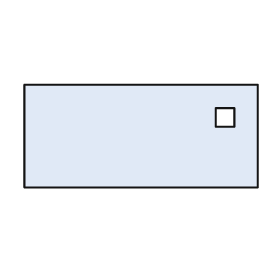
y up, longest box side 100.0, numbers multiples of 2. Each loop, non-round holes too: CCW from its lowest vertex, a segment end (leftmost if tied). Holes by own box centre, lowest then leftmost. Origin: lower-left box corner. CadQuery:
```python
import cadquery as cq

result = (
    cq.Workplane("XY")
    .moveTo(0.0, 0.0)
    .lineTo(100.0, 0.0)
    .lineTo(100.0, 44.0)
    .lineTo(0.0, 44.0)
    .close()
    .moveTo(82.0, 26.0)
    .lineTo(90.0, 26.0)
    .lineTo(90.0, 34.0)
    .lineTo(82.0, 34.0)
    .close()
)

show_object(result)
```